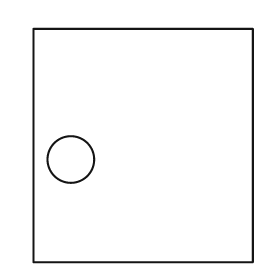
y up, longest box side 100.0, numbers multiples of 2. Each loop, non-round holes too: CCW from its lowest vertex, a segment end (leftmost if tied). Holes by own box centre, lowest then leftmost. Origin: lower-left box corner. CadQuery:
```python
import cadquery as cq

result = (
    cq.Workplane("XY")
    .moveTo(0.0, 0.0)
    .lineTo(94.0, 0.0)
    .lineTo(94.0, 100.0)
    .lineTo(0.0, 100.0)
    .close()
    .moveTo(16.0, 44.0)
    .circle(10.0)
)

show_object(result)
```